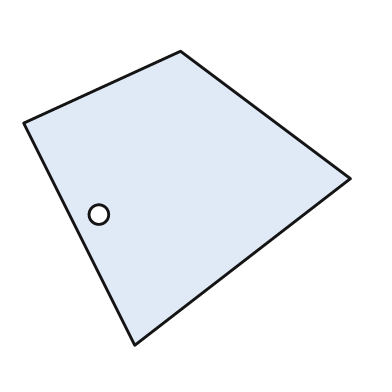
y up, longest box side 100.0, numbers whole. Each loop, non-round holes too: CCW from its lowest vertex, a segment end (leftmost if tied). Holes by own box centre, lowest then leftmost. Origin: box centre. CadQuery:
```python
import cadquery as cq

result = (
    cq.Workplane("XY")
    .moveTo(-16.0, -45.0)
    .lineTo(50.0, 6.0)
    .lineTo(-2.0, 45.0)
    .lineTo(-50.0, 23.0)
    .close()
    .moveTo(-27.0, -5.0)
    .circle(3.0)
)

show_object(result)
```